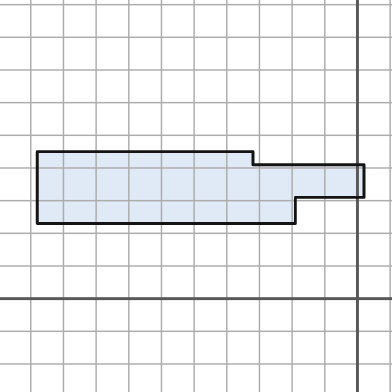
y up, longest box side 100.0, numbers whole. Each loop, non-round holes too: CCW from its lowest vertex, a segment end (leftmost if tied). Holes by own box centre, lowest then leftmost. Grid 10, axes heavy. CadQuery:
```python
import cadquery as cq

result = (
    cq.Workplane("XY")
    .moveTo(-98.0, 23.0)
    .lineTo(-19.0, 23.0)
    .lineTo(-19.0, 31.0)
    .lineTo(2.0, 31.0)
    .lineTo(2.0, 41.0)
    .lineTo(-32.0, 41.0)
    .lineTo(-32.0, 45.0)
    .lineTo(-98.0, 45.0)
    .close()
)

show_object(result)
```